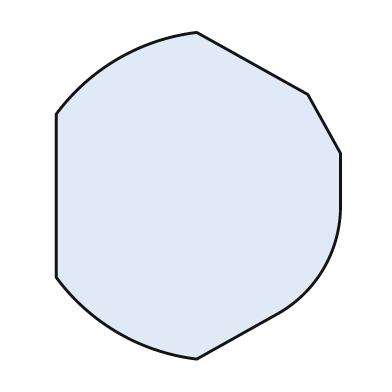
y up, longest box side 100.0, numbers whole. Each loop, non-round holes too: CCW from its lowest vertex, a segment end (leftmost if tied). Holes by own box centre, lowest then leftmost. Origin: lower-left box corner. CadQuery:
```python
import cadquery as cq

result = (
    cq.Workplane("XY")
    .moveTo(43.0, 0.0)
    .lineTo(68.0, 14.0)
    .threePointArc((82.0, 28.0), (87.0, 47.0))
    .lineTo(87.0, 63.0)
    .lineTo(77.0, 81.0)
    .lineTo(43.0, 100.0)
    .threePointArc((19.0, 92.0), (0.0, 75.0))
    .lineTo(0.0, 25.0)
    .threePointArc((19.0, 8.0), (43.0, 0.0))
    .close()
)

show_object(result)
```